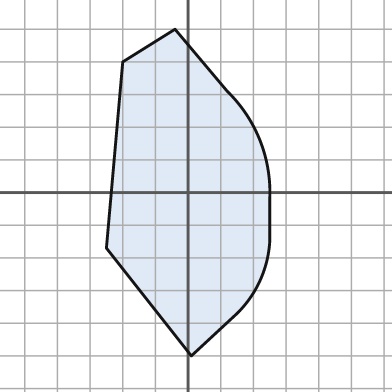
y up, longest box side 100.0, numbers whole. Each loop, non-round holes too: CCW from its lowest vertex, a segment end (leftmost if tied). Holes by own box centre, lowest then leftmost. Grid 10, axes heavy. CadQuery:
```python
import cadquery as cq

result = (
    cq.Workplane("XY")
    .moveTo(1.0, -50.0)
    .lineTo(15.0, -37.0)
    .threePointArc((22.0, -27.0), (25.0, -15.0))
    .lineTo(25.0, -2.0)
    .threePointArc((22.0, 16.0), (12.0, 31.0))
    .lineTo(-4.0, 50.0)
    .lineTo(-20.0, 40.0)
    .lineTo(-25.0, -17.0)
    .close()
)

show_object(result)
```